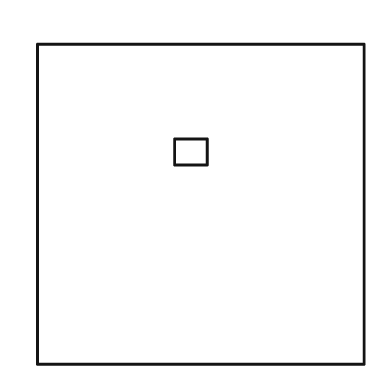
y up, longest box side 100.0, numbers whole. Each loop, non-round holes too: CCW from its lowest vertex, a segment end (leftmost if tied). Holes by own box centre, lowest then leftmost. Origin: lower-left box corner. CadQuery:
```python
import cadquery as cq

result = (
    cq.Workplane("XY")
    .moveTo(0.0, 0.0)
    .lineTo(100.0, 0.0)
    .lineTo(100.0, 98.0)
    .lineTo(0.0, 98.0)
    .close()
    .moveTo(42.0, 61.0)
    .lineTo(52.0, 61.0)
    .lineTo(52.0, 69.0)
    .lineTo(42.0, 69.0)
    .close()
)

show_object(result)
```